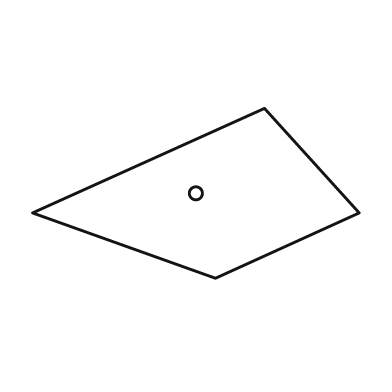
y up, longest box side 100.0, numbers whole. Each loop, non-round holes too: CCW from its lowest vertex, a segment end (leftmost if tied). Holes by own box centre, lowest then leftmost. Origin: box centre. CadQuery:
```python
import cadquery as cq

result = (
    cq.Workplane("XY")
    .moveTo(6.0, -26.0)
    .lineTo(50.0, -6.0)
    .lineTo(21.0, 26.0)
    .lineTo(-50.0, -6.0)
    .close()
    .moveTo(0.0, 0.0)
    .circle(2.0)
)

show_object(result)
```